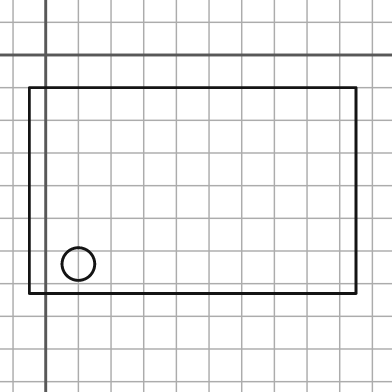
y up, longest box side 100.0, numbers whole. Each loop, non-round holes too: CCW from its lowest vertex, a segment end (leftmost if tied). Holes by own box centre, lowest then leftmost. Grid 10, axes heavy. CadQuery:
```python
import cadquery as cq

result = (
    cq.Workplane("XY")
    .moveTo(-5.0, -73.0)
    .lineTo(95.0, -73.0)
    .lineTo(95.0, -10.0)
    .lineTo(-5.0, -10.0)
    .close()
    .moveTo(10.0, -64.0)
    .circle(5.0)
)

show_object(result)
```